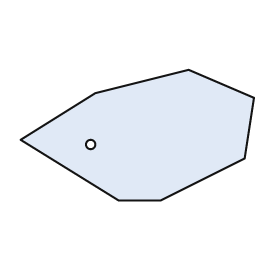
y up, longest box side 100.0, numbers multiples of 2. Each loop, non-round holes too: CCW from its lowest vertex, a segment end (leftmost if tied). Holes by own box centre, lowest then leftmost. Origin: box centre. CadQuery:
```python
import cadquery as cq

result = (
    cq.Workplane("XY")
    .moveTo(-8.0, -28.0)
    .lineTo(10.0, -28.0)
    .lineTo(46.0, -10.0)
    .lineTo(50.0, 16.0)
    .lineTo(22.0, 28.0)
    .lineTo(-18.0, 18.0)
    .lineTo(-50.0, -2.0)
    .close()
    .moveTo(-20.0, -4.0)
    .circle(2.0)
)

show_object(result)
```